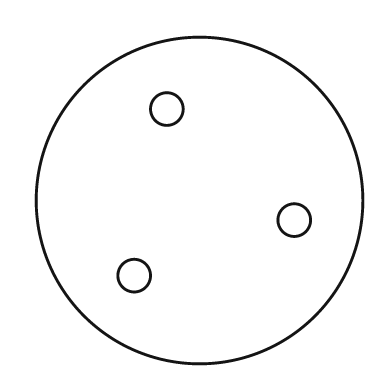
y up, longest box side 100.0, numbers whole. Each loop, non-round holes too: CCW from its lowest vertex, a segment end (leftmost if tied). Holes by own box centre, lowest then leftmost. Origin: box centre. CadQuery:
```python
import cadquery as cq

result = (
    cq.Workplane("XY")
    .moveTo(0.0, 0.0)
    .circle(50.0)
    .moveTo(-20.0, -23.0)
    .circle(5.0)
    .moveTo(29.0, -6.0)
    .circle(5.0)
    .moveTo(-10.0, 28.0)
    .circle(5.0)
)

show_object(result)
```